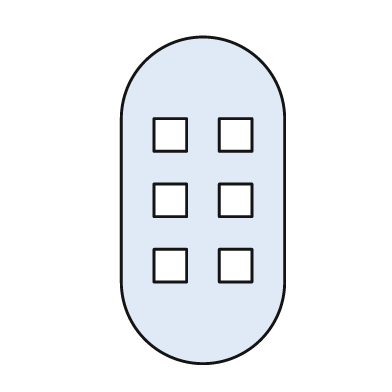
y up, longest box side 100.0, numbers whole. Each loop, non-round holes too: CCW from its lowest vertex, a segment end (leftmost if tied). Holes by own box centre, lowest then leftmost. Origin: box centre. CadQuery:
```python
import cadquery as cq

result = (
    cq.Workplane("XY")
    .moveTo(-25.0, -25.0)
    .threePointArc((0.0, -50.0), (25.0, -25.0))
    .lineTo(25.0, 25.0)
    .threePointArc((0.0, 50.0), (-25.0, 25.0))
    .close()
    .moveTo(-15.0, -25.0)
    .lineTo(-5.0, -25.0)
    .lineTo(-5.0, -15.0)
    .lineTo(-15.0, -15.0)
    .close()
    .moveTo(5.0, -25.0)
    .lineTo(15.0, -25.0)
    .lineTo(15.0, -15.0)
    .lineTo(5.0, -15.0)
    .close()
    .moveTo(-15.0, -5.0)
    .lineTo(-5.0, -5.0)
    .lineTo(-5.0, 5.0)
    .lineTo(-15.0, 5.0)
    .close()
    .moveTo(5.0, -5.0)
    .lineTo(15.0, -5.0)
    .lineTo(15.0, 5.0)
    .lineTo(5.0, 5.0)
    .close()
    .moveTo(-15.0, 15.0)
    .lineTo(-5.0, 15.0)
    .lineTo(-5.0, 25.0)
    .lineTo(-15.0, 25.0)
    .close()
    .moveTo(5.0, 15.0)
    .lineTo(15.0, 15.0)
    .lineTo(15.0, 25.0)
    .lineTo(5.0, 25.0)
    .close()
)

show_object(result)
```